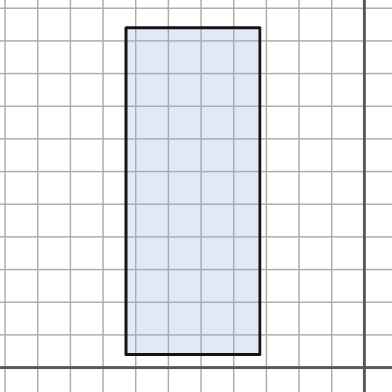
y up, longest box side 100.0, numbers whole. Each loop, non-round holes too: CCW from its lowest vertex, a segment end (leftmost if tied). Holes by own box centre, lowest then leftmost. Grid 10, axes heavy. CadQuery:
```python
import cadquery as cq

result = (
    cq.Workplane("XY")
    .moveTo(-73.0, 4.0)
    .lineTo(-32.0, 4.0)
    .lineTo(-32.0, 104.0)
    .lineTo(-73.0, 104.0)
    .close()
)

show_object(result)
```